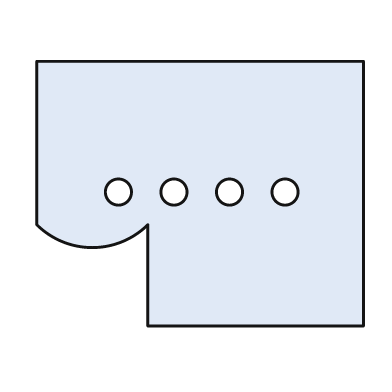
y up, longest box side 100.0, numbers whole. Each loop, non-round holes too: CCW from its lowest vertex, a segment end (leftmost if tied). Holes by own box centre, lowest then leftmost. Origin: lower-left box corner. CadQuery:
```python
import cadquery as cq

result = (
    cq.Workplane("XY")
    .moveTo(34.0, 0.0)
    .lineTo(100.0, 0.0)
    .lineTo(100.0, 81.0)
    .lineTo(0.0, 81.0)
    .lineTo(0.0, 31.0)
    .threePointArc((17.0, 24.0), (34.0, 31.0))
    .close()
    .moveTo(25.0, 41.0)
    .circle(4.0)
    .moveTo(42.0, 41.0)
    .circle(4.0)
    .moveTo(59.0, 41.0)
    .circle(4.0)
    .moveTo(76.0, 41.0)
    .circle(4.0)
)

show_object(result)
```